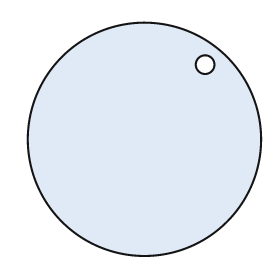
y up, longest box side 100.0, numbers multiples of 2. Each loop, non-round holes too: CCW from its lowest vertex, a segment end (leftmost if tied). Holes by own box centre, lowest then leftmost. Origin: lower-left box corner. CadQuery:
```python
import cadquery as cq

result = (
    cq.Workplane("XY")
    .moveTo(50.0, 50.0)
    .circle(50.0)
    .moveTo(76.0, 82.0)
    .circle(4.0)
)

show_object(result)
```